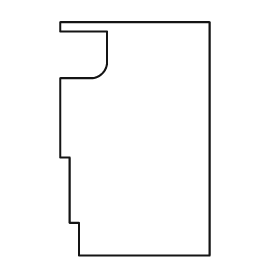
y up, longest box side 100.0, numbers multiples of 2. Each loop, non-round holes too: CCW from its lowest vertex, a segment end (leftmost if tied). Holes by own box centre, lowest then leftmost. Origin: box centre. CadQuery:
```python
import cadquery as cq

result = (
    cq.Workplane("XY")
    .moveTo(-24.0, -50.0)
    .lineTo(32.0, -50.0)
    .lineTo(32.0, 50.0)
    .lineTo(-32.0, 50.0)
    .lineTo(-32.0, 46.0)
    .lineTo(-12.0, 46.0)
    .lineTo(-12.0, 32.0)
    .threePointArc((-14.0, 28.0), (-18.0, 26.0))
    .lineTo(-32.0, 26.0)
    .lineTo(-32.0, -8.0)
    .lineTo(-28.0, -8.0)
    .lineTo(-28.0, -36.0)
    .lineTo(-24.0, -36.0)
    .close()
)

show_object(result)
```